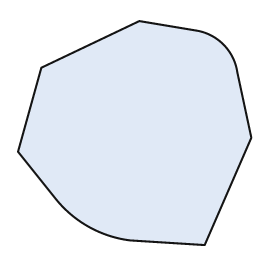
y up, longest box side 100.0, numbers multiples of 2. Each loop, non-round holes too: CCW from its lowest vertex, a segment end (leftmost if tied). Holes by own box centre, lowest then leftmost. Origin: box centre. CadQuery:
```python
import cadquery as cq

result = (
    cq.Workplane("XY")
    .moveTo(30.0, -48.0)
    .lineTo(50.0, -2.0)
    .lineTo(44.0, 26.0)
    .threePointArc((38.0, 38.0), (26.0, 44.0))
    .lineTo(2.0, 48.0)
    .lineTo(-40.0, 28.0)
    .lineTo(-50.0, -8.0)
    .lineTo(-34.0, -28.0)
    .threePointArc((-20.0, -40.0), (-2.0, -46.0))
    .close()
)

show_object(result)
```